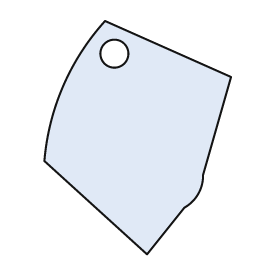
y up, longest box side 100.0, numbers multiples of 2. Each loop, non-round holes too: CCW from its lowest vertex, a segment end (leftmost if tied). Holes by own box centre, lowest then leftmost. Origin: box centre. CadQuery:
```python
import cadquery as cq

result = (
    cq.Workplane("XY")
    .moveTo(4.0, -50.0)
    .lineTo(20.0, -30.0)
    .threePointArc((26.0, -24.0), (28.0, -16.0))
    .lineTo(40.0, 26.0)
    .lineTo(-14.0, 50.0)
    .threePointArc((-32.0, 22.0), (-40.0, -10.0))
    .close()
    .moveTo(-10.0, 36.0)
    .circle(6.0)
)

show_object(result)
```